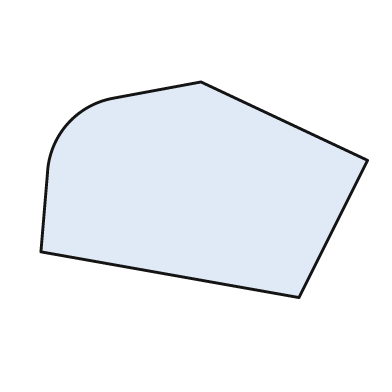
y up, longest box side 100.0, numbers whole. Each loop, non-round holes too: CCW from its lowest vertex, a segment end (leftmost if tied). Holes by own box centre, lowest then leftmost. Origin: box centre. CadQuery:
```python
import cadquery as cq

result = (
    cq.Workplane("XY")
    .moveTo(29.0, -33.0)
    .lineTo(50.0, 9.0)
    .lineTo(-1.0, 33.0)
    .lineTo(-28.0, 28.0)
    .threePointArc((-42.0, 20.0), (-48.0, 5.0))
    .lineTo(-50.0, -19.0)
    .close()
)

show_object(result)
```